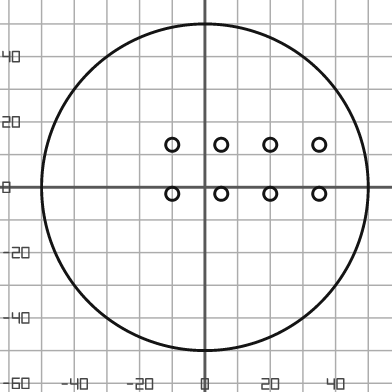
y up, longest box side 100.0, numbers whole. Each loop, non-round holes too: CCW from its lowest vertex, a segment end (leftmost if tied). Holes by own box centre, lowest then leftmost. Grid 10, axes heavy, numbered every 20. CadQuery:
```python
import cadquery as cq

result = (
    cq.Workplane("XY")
    .moveTo(0.0, 0.0)
    .circle(50.0)
    .moveTo(-10.0, -2.0)
    .circle(2.0)
    .moveTo(5.0, -2.0)
    .circle(2.0)
    .moveTo(20.0, -2.0)
    .circle(2.0)
    .moveTo(35.0, -2.0)
    .circle(2.0)
    .moveTo(-10.0, 13.0)
    .circle(2.0)
    .moveTo(5.0, 13.0)
    .circle(2.0)
    .moveTo(20.0, 13.0)
    .circle(2.0)
    .moveTo(35.0, 13.0)
    .circle(2.0)
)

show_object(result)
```